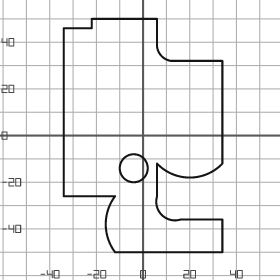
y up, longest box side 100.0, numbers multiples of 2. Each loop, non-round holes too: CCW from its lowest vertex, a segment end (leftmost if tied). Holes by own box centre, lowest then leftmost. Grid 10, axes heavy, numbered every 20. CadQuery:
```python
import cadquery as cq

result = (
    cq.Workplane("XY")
    .moveTo(-12.0, -50.0)
    .lineTo(34.0, -50.0)
    .lineTo(34.0, -36.0)
    .lineTo(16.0, -36.0)
    .threePointArc((8.0, -34.0), (6.0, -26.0))
    .lineTo(6.0, -12.0)
    .threePointArc((20.0, -18.0), (34.0, -12.0))
    .lineTo(34.0, 32.0)
    .lineTo(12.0, 32.0)
    .threePointArc((8.0, 34.0), (6.0, 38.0))
    .lineTo(6.0, 50.0)
    .lineTo(-22.0, 50.0)
    .lineTo(-22.0, 46.0)
    .lineTo(-34.0, 46.0)
    .lineTo(-34.0, -26.0)
    .lineTo(-12.0, -26.0)
    .threePointArc((-16.0, -38.0), (-12.0, -50.0))
    .close()
    .moveTo(-4.0, -14.0)
    .circle(6.0)
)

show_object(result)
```